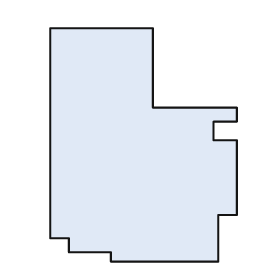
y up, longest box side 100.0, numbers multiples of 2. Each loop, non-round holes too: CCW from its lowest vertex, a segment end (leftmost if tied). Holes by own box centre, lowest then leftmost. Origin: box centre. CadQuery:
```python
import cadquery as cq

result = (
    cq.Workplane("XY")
    .moveTo(-14.0, -50.0)
    .lineTo(32.0, -50.0)
    .lineTo(32.0, -30.0)
    .lineTo(40.0, -30.0)
    .lineTo(40.0, 2.0)
    .lineTo(30.0, 2.0)
    .lineTo(30.0, 10.0)
    .lineTo(40.0, 10.0)
    .lineTo(40.0, 16.0)
    .lineTo(4.0, 16.0)
    .lineTo(4.0, 50.0)
    .lineTo(-40.0, 50.0)
    .lineTo(-40.0, -40.0)
    .lineTo(-32.0, -40.0)
    .lineTo(-32.0, -46.0)
    .lineTo(-14.0, -46.0)
    .close()
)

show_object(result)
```